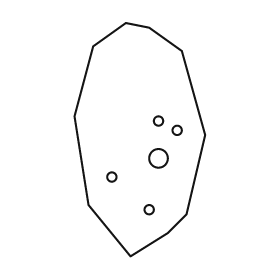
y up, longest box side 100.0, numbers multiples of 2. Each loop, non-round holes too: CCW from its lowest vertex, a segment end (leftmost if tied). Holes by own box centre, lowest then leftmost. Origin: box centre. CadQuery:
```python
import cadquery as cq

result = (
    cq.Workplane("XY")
    .moveTo(-4.0, -50.0)
    .lineTo(12.0, -40.0)
    .lineTo(20.0, -32.0)
    .lineTo(28.0, 2.0)
    .lineTo(18.0, 38.0)
    .lineTo(4.0, 48.0)
    .lineTo(-6.0, 50.0)
    .lineTo(-20.0, 40.0)
    .lineTo(-28.0, 10.0)
    .lineTo(-22.0, -28.0)
    .close()
    .moveTo(4.0, -30.0)
    .circle(2.0)
    .moveTo(-12.0, -16.0)
    .circle(2.0)
    .moveTo(8.0, -8.0)
    .circle(4.0)
    .moveTo(16.0, 4.0)
    .circle(2.0)
    .moveTo(8.0, 8.0)
    .circle(2.0)
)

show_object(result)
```